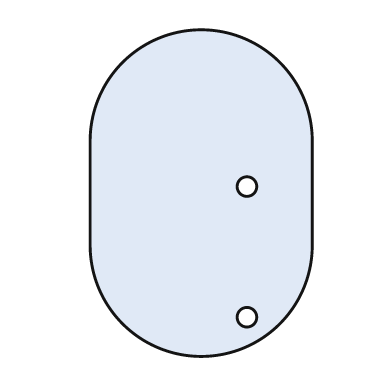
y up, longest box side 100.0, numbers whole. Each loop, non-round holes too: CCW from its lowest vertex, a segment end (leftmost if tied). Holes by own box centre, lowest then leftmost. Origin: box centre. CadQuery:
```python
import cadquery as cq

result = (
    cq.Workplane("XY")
    .moveTo(-34.0, -16.0)
    .threePointArc((0.0, -50.0), (34.0, -16.0))
    .lineTo(34.0, 16.0)
    .threePointArc((0.0, 50.0), (-34.0, 16.0))
    .close()
    .moveTo(14.0, -38.0)
    .circle(3.0)
    .moveTo(14.0, 2.0)
    .circle(3.0)
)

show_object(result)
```